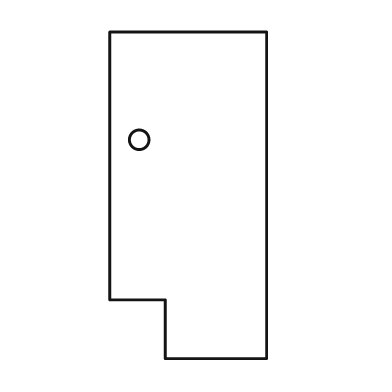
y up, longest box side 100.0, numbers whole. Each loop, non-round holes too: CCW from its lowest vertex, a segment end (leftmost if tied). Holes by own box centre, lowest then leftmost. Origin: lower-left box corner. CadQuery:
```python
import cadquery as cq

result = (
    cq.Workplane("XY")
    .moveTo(17.0, 0.0)
    .lineTo(48.0, 0.0)
    .lineTo(48.0, 100.0)
    .lineTo(0.0, 100.0)
    .lineTo(0.0, 18.0)
    .lineTo(17.0, 18.0)
    .close()
    .moveTo(9.0, 67.0)
    .circle(3.0)
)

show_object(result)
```